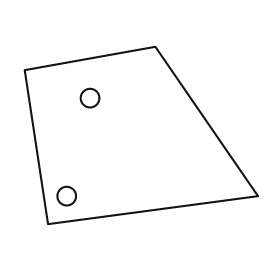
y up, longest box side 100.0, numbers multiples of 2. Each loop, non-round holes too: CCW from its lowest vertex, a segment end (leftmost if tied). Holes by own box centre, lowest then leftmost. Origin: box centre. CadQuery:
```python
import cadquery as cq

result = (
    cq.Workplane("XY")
    .moveTo(-40.0, -38.0)
    .lineTo(50.0, -26.0)
    .lineTo(6.0, 38.0)
    .lineTo(-50.0, 28.0)
    .close()
    .moveTo(-32.0, -26.0)
    .circle(4.0)
    .moveTo(-22.0, 16.0)
    .circle(4.0)
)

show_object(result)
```